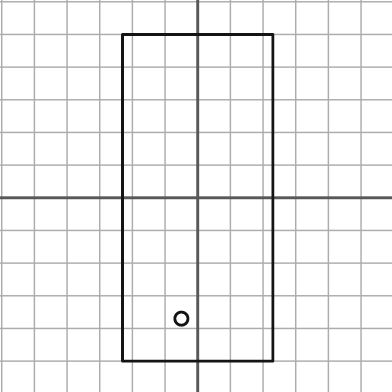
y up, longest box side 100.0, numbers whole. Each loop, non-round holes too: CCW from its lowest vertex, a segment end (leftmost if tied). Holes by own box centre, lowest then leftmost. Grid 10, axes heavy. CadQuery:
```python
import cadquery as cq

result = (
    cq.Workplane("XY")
    .moveTo(-23.0, -50.0)
    .lineTo(23.0, -50.0)
    .lineTo(23.0, 50.0)
    .lineTo(-23.0, 50.0)
    .close()
    .moveTo(-5.0, -37.0)
    .circle(2.0)
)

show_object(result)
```